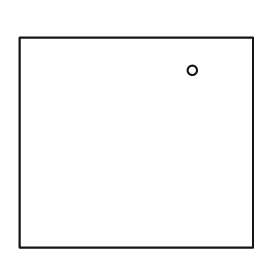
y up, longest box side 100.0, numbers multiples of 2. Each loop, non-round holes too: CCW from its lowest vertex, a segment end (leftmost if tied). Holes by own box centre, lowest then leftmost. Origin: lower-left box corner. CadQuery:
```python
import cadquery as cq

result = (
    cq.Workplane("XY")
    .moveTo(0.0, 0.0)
    .lineTo(100.0, 0.0)
    .lineTo(100.0, 90.0)
    .lineTo(0.0, 90.0)
    .close()
    .moveTo(74.0, 76.0)
    .circle(2.0)
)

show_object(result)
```